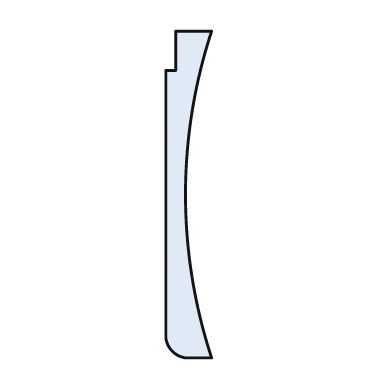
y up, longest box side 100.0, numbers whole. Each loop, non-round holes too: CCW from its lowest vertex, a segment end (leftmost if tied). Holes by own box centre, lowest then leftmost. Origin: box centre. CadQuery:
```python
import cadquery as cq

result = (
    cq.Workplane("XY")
    .moveTo(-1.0, -50.0)
    .lineTo(7.0, -50.0)
    .threePointArc((-1.0, 0.0), (7.0, 50.0))
    .lineTo(-4.0, 50.0)
    .lineTo(-4.0, 38.0)
    .lineTo(-7.0, 38.0)
    .lineTo(-7.0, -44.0)
    .threePointArc((-5.0, -48.0), (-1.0, -50.0))
    .close()
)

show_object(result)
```